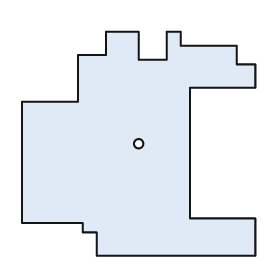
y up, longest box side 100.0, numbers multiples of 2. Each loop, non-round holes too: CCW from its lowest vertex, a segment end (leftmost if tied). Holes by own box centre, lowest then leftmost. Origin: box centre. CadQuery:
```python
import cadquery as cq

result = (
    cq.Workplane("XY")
    .moveTo(-18.0, -48.0)
    .lineTo(50.0, -48.0)
    .lineTo(50.0, -32.0)
    .lineTo(22.0, -32.0)
    .lineTo(22.0, 24.0)
    .lineTo(50.0, 24.0)
    .lineTo(50.0, 34.0)
    .lineTo(42.0, 34.0)
    .lineTo(42.0, 42.0)
    .lineTo(18.0, 42.0)
    .lineTo(18.0, 48.0)
    .lineTo(12.0, 48.0)
    .lineTo(12.0, 36.0)
    .lineTo(0.0, 36.0)
    .lineTo(0.0, 48.0)
    .lineTo(-14.0, 48.0)
    .lineTo(-14.0, 38.0)
    .lineTo(-26.0, 38.0)
    .lineTo(-26.0, 18.0)
    .lineTo(-50.0, 18.0)
    .lineTo(-50.0, -34.0)
    .lineTo(-24.0, -34.0)
    .lineTo(-24.0, -38.0)
    .lineTo(-18.0, -38.0)
    .close()
    .moveTo(0.0, 0.0)
    .circle(2.0)
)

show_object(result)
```